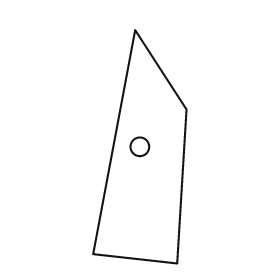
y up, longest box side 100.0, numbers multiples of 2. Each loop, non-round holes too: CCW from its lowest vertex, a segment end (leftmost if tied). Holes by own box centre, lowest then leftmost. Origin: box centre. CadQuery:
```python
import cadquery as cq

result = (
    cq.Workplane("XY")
    .moveTo(16.0, -50.0)
    .lineTo(20.0, 16.0)
    .lineTo(-2.0, 50.0)
    .lineTo(-20.0, -46.0)
    .close()
    .moveTo(0.0, 0.0)
    .circle(4.0)
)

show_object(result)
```